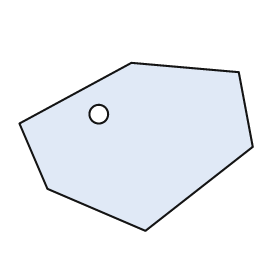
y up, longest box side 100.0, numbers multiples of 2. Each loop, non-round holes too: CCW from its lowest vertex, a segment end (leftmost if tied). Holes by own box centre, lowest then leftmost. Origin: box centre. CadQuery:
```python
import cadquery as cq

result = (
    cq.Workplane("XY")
    .moveTo(4.0, -36.0)
    .lineTo(50.0, 0.0)
    .lineTo(44.0, 32.0)
    .lineTo(-2.0, 36.0)
    .lineTo(-50.0, 10.0)
    .lineTo(-38.0, -18.0)
    .close()
    .moveTo(-16.0, 14.0)
    .circle(4.0)
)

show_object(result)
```